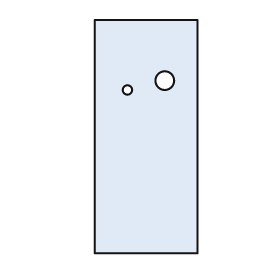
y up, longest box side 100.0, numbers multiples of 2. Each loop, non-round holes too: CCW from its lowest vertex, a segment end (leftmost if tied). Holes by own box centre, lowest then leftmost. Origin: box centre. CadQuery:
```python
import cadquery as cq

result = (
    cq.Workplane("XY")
    .moveTo(-22.0, -50.0)
    .lineTo(22.0, -50.0)
    .lineTo(22.0, 50.0)
    .lineTo(-22.0, 50.0)
    .close()
    .moveTo(-8.0, 20.0)
    .circle(2.0)
    .moveTo(8.0, 24.0)
    .circle(4.0)
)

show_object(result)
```